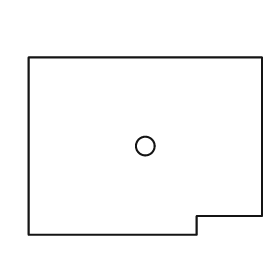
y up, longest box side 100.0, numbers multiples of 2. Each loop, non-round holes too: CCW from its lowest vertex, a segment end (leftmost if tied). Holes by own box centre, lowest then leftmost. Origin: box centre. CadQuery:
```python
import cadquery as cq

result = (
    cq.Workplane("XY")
    .moveTo(-50.0, -38.0)
    .lineTo(22.0, -38.0)
    .lineTo(22.0, -30.0)
    .lineTo(50.0, -30.0)
    .lineTo(50.0, 38.0)
    .lineTo(-50.0, 38.0)
    .close()
    .moveTo(0.0, 0.0)
    .circle(4.0)
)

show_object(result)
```